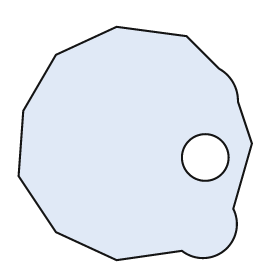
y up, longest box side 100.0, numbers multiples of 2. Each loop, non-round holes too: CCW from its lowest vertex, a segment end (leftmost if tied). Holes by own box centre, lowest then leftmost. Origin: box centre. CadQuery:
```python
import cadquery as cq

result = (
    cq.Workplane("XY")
    .moveTo(-8.0, -50.0)
    .lineTo(20.0, -46.0)
    .threePointArc((38.0, -46.0), (42.0, -28.0))
    .lineTo(50.0, 0.0)
    .lineTo(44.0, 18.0)
    .threePointArc((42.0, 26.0), (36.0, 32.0))
    .lineTo(22.0, 46.0)
    .lineTo(-8.0, 50.0)
    .lineTo(-34.0, 38.0)
    .lineTo(-48.0, 14.0)
    .lineTo(-50.0, -14.0)
    .lineTo(-34.0, -38.0)
    .close()
    .moveTo(30.0, -6.0)
    .circle(10.0)
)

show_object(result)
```